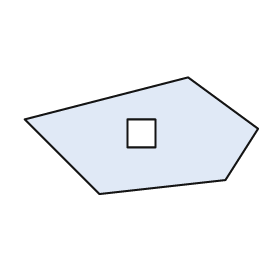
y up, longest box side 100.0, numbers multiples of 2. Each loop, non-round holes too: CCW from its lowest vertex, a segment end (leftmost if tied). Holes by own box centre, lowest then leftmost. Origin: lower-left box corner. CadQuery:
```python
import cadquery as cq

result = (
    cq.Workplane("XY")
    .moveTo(32.0, 0.0)
    .lineTo(86.0, 6.0)
    .lineTo(100.0, 28.0)
    .lineTo(70.0, 50.0)
    .lineTo(0.0, 32.0)
    .close()
    .moveTo(44.0, 20.0)
    .lineTo(56.0, 20.0)
    .lineTo(56.0, 32.0)
    .lineTo(44.0, 32.0)
    .close()
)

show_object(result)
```